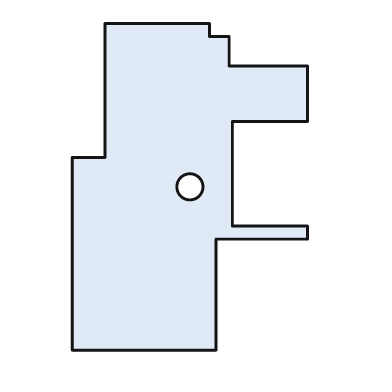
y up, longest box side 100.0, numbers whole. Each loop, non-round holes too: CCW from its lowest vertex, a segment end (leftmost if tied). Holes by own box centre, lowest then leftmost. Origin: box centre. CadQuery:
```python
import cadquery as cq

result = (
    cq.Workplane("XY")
    .moveTo(-36.0, -50.0)
    .lineTo(8.0, -50.0)
    .lineTo(8.0, -16.0)
    .lineTo(36.0, -16.0)
    .lineTo(36.0, -12.0)
    .lineTo(13.0, -12.0)
    .lineTo(13.0, 20.0)
    .lineTo(36.0, 20.0)
    .lineTo(36.0, 37.0)
    .lineTo(12.0, 37.0)
    .lineTo(12.0, 46.0)
    .lineTo(6.0, 46.0)
    .lineTo(6.0, 50.0)
    .lineTo(-26.0, 50.0)
    .lineTo(-26.0, 9.0)
    .lineTo(-36.0, 9.0)
    .close()
    .moveTo(0.0, 0.0)
    .circle(4.0)
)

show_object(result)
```